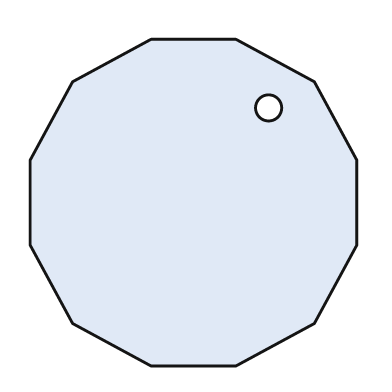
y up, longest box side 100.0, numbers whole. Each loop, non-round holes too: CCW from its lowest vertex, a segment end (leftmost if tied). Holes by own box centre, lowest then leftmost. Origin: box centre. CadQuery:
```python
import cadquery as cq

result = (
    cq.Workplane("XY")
    .moveTo(-13.0, -50.0)
    .lineTo(13.0, -50.0)
    .lineTo(37.0, -37.0)
    .lineTo(50.0, -13.0)
    .lineTo(50.0, 13.0)
    .lineTo(37.0, 37.0)
    .lineTo(13.0, 50.0)
    .lineTo(-13.0, 50.0)
    .lineTo(-37.0, 37.0)
    .lineTo(-50.0, 13.0)
    .lineTo(-50.0, -13.0)
    .lineTo(-37.0, -37.0)
    .close()
    .moveTo(23.0, 29.0)
    .circle(4.0)
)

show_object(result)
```